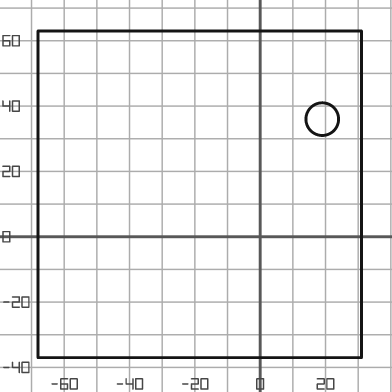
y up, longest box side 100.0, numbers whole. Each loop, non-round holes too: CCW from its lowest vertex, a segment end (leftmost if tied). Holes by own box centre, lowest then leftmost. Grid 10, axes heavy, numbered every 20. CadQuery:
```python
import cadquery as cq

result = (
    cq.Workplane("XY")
    .moveTo(-68.0, -37.0)
    .lineTo(31.0, -37.0)
    .lineTo(31.0, 63.0)
    .lineTo(-68.0, 63.0)
    .close()
    .moveTo(19.0, 36.0)
    .circle(5.0)
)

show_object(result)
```